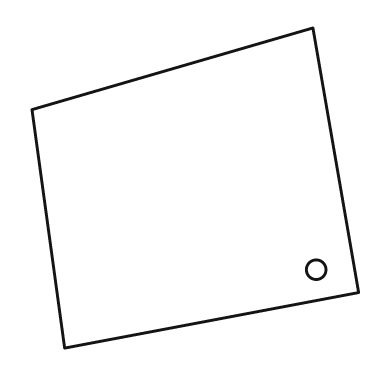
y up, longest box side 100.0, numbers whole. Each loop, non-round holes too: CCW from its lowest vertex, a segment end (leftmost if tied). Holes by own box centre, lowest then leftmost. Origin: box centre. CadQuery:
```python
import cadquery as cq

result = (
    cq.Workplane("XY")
    .moveTo(-40.0, -49.0)
    .lineTo(50.0, -32.0)
    .lineTo(36.0, 49.0)
    .lineTo(-50.0, 24.0)
    .close()
    .moveTo(37.0, -25.0)
    .circle(3.0)
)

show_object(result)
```